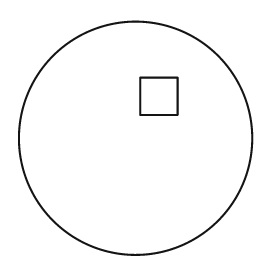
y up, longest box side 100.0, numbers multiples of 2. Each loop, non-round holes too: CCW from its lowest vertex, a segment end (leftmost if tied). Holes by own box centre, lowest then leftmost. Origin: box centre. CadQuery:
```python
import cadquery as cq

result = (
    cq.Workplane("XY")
    .moveTo(0.0, 0.0)
    .circle(50.0)
    .moveTo(2.0, 10.0)
    .lineTo(18.0, 10.0)
    .lineTo(18.0, 26.0)
    .lineTo(2.0, 26.0)
    .close()
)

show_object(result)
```